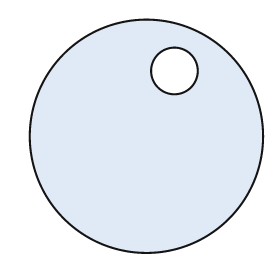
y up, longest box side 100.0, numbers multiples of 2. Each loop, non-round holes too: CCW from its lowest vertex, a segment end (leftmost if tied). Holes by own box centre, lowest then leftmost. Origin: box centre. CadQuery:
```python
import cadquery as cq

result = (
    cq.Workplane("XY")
    .moveTo(0.0, 0.0)
    .circle(50.0)
    .moveTo(12.0, 28.0)
    .circle(10.0)
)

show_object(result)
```